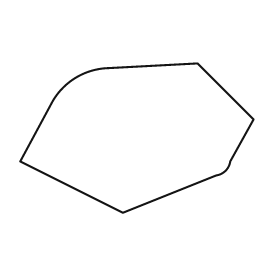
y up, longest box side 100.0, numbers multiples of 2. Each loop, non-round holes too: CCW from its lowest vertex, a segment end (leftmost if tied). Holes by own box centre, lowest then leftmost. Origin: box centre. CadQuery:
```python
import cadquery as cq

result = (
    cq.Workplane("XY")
    .moveTo(-6.0, -32.0)
    .lineTo(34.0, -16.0)
    .threePointArc((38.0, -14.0), (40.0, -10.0))
    .lineTo(50.0, 8.0)
    .lineTo(26.0, 32.0)
    .lineTo(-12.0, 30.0)
    .threePointArc((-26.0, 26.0), (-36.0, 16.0))
    .lineTo(-50.0, -10.0)
    .close()
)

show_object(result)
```